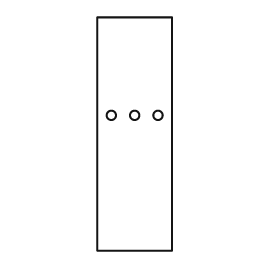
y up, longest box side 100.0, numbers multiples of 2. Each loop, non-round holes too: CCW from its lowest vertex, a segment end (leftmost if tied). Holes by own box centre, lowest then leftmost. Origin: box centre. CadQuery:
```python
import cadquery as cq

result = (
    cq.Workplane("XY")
    .moveTo(-16.0, -50.0)
    .lineTo(16.0, -50.0)
    .lineTo(16.0, 50.0)
    .lineTo(-16.0, 50.0)
    .close()
    .moveTo(-10.0, 8.0)
    .circle(2.0)
    .moveTo(0.0, 8.0)
    .circle(2.0)
    .moveTo(10.0, 8.0)
    .circle(2.0)
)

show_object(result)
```